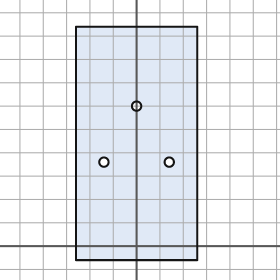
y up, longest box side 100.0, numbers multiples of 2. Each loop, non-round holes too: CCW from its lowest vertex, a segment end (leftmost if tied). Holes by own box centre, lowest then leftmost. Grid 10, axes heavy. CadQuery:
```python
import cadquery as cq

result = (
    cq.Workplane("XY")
    .moveTo(-26.0, -6.0)
    .lineTo(26.0, -6.0)
    .lineTo(26.0, 94.0)
    .lineTo(-26.0, 94.0)
    .close()
    .moveTo(-14.0, 36.0)
    .circle(2.0)
    .moveTo(14.0, 36.0)
    .circle(2.0)
    .moveTo(0.0, 60.0)
    .circle(2.0)
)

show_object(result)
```